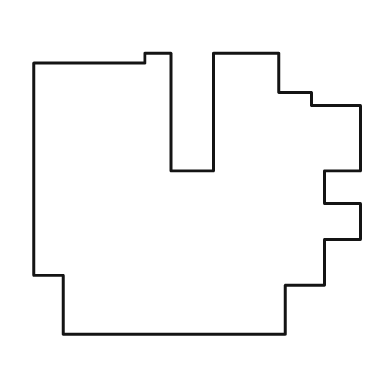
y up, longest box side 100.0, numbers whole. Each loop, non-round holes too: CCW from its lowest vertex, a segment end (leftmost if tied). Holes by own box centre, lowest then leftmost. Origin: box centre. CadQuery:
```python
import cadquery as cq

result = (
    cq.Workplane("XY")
    .moveTo(-41.0, -43.0)
    .lineTo(27.0, -43.0)
    .lineTo(27.0, -28.0)
    .lineTo(39.0, -28.0)
    .lineTo(39.0, -14.0)
    .lineTo(50.0, -14.0)
    .lineTo(50.0, -3.0)
    .lineTo(39.0, -3.0)
    .lineTo(39.0, 7.0)
    .lineTo(50.0, 7.0)
    .lineTo(50.0, 27.0)
    .lineTo(35.0, 27.0)
    .lineTo(35.0, 31.0)
    .lineTo(25.0, 31.0)
    .lineTo(25.0, 43.0)
    .lineTo(5.0, 43.0)
    .lineTo(5.0, 7.0)
    .lineTo(-8.0, 7.0)
    .lineTo(-8.0, 43.0)
    .lineTo(-16.0, 43.0)
    .lineTo(-16.0, 40.0)
    .lineTo(-50.0, 40.0)
    .lineTo(-50.0, -25.0)
    .lineTo(-41.0, -25.0)
    .close()
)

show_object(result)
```